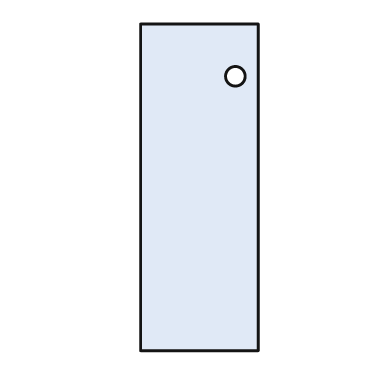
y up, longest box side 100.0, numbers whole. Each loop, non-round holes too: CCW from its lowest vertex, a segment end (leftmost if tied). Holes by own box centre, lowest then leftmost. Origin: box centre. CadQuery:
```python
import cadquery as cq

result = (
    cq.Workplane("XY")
    .moveTo(-18.0, -50.0)
    .lineTo(18.0, -50.0)
    .lineTo(18.0, 50.0)
    .lineTo(-18.0, 50.0)
    .close()
    .moveTo(11.0, 34.0)
    .circle(3.0)
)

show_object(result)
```